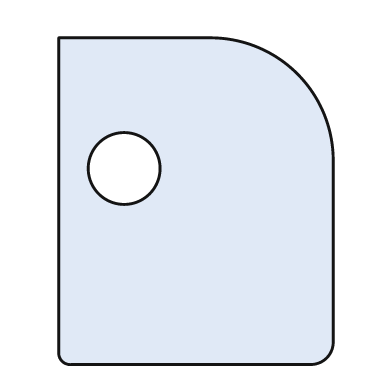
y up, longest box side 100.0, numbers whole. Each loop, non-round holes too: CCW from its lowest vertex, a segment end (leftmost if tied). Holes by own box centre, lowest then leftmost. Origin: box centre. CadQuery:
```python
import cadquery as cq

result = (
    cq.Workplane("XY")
    .moveTo(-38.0, -50.0)
    .lineTo(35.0, -50.0)
    .threePointArc((40.0, -48.0), (42.0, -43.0))
    .lineTo(42.0, 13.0)
    .threePointArc((31.0, 39.0), (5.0, 50.0))
    .lineTo(-42.0, 50.0)
    .lineTo(-42.0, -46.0)
    .threePointArc((-41.0, -49.0), (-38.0, -50.0))
    .close()
    .moveTo(-22.0, 10.0)
    .circle(11.0)
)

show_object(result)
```